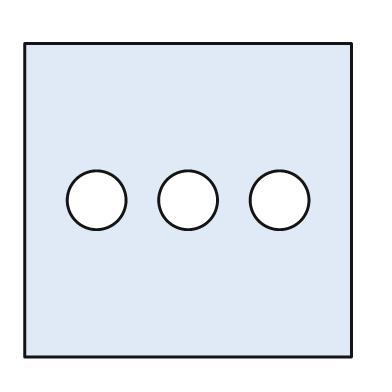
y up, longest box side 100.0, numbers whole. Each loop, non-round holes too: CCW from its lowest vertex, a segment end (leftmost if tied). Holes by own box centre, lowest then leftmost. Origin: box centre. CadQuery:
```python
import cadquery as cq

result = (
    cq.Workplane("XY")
    .moveTo(-50.0, -48.0)
    .lineTo(50.0, -48.0)
    .lineTo(50.0, 48.0)
    .lineTo(-50.0, 48.0)
    .close()
    .moveTo(-28.0, 0.0)
    .circle(9.0)
    .moveTo(0.0, 0.0)
    .circle(9.0)
    .moveTo(28.0, 0.0)
    .circle(9.0)
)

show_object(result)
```